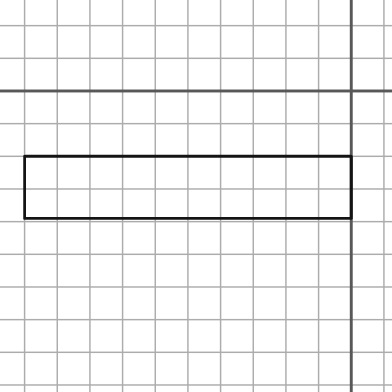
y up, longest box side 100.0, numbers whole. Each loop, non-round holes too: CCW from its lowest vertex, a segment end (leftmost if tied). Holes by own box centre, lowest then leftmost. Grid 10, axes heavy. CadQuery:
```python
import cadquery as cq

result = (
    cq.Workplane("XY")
    .moveTo(-100.0, -39.0)
    .lineTo(0.0, -39.0)
    .lineTo(0.0, -20.0)
    .lineTo(-100.0, -20.0)
    .close()
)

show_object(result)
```